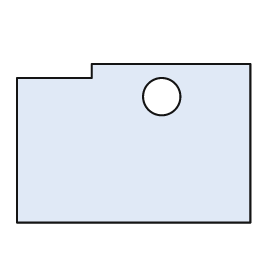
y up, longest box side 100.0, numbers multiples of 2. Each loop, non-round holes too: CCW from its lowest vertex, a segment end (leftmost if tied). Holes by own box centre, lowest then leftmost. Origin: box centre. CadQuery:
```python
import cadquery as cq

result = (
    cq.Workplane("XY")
    .moveTo(-50.0, -34.0)
    .lineTo(50.0, -34.0)
    .lineTo(50.0, 34.0)
    .lineTo(-18.0, 34.0)
    .lineTo(-18.0, 28.0)
    .lineTo(-50.0, 28.0)
    .close()
    .moveTo(12.0, 20.0)
    .circle(8.0)
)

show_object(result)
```